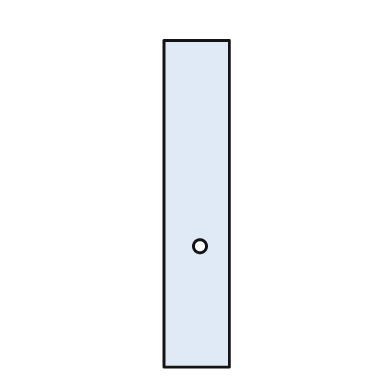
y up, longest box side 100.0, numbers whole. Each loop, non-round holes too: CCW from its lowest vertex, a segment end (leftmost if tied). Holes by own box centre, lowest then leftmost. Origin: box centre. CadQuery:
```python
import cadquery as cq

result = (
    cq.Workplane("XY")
    .moveTo(-10.0, -50.0)
    .lineTo(10.0, -50.0)
    .lineTo(10.0, 50.0)
    .lineTo(-10.0, 50.0)
    .close()
    .moveTo(1.0, -13.0)
    .circle(2.0)
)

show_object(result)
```